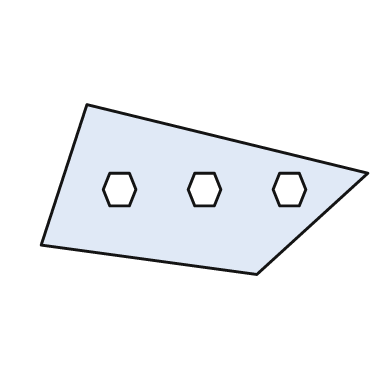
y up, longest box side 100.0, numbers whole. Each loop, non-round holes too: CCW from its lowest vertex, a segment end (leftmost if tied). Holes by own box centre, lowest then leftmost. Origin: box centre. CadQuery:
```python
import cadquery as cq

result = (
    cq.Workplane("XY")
    .moveTo(16.0, -26.0)
    .lineTo(50.0, 5.0)
    .lineTo(-36.0, 26.0)
    .lineTo(-50.0, -17.0)
    .close()
    .moveTo(-29.0, -5.0)
    .lineTo(-23.0, -5.0)
    .lineTo(-21.0, 0.0)
    .lineTo(-23.0, 5.0)
    .lineTo(-29.0, 5.0)
    .lineTo(-31.0, 0.0)
    .close()
    .moveTo(-3.0, -5.0)
    .lineTo(3.0, -5.0)
    .lineTo(5.0, 0.0)
    .lineTo(3.0, 5.0)
    .lineTo(-3.0, 5.0)
    .lineTo(-5.0, 0.0)
    .close()
    .moveTo(23.0, -5.0)
    .lineTo(29.0, -5.0)
    .lineTo(31.0, 0.0)
    .lineTo(29.0, 5.0)
    .lineTo(23.0, 5.0)
    .lineTo(21.0, 0.0)
    .close()
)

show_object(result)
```